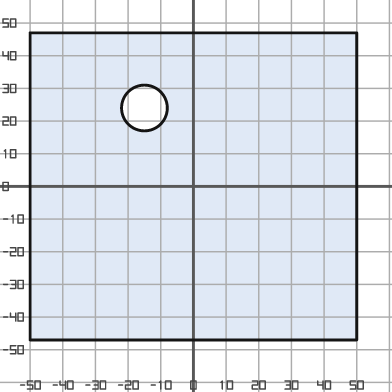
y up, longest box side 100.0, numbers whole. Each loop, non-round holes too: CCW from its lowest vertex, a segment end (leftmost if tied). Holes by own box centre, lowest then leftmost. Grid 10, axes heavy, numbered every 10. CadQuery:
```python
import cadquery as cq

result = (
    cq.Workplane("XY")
    .moveTo(-50.0, -47.0)
    .lineTo(50.0, -47.0)
    .lineTo(50.0, 47.0)
    .lineTo(-50.0, 47.0)
    .close()
    .moveTo(-15.0, 24.0)
    .circle(7.0)
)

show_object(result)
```